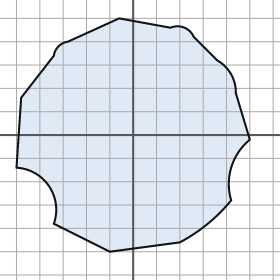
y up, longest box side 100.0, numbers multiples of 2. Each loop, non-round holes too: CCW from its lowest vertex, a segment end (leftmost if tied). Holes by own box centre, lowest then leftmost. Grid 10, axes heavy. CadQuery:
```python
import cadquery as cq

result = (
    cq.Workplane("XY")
    .moveTo(-10.0, -50.0)
    .lineTo(20.0, -46.0)
    .threePointArc((32.0, -38.0), (42.0, -28.0))
    .threePointArc((42.0, -14.0), (50.0, -2.0))
    .lineTo(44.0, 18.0)
    .threePointArc((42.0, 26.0), (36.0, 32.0))
    .lineTo(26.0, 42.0)
    .threePointArc((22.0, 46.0), (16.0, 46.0))
    .lineTo(-6.0, 50.0)
    .lineTo(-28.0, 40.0)
    .threePointArc((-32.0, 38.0), (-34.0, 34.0))
    .lineTo(-48.0, 16.0)
    .lineTo(-50.0, -14.0)
    .threePointArc((-36.0, -22.0), (-34.0, -38.0))
    .close()
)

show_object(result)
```